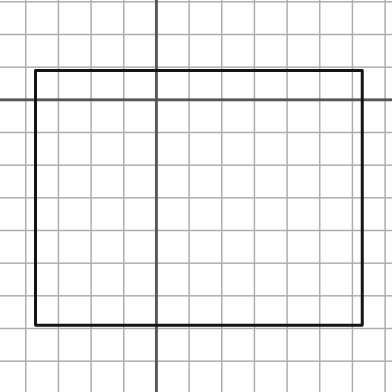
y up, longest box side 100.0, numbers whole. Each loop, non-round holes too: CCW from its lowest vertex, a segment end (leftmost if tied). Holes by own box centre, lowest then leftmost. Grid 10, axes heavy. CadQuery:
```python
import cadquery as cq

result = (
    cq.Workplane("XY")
    .moveTo(-37.0, -69.0)
    .lineTo(63.0, -69.0)
    .lineTo(63.0, 9.0)
    .lineTo(-37.0, 9.0)
    .close()
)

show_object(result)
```